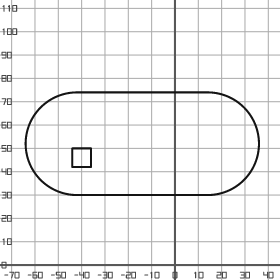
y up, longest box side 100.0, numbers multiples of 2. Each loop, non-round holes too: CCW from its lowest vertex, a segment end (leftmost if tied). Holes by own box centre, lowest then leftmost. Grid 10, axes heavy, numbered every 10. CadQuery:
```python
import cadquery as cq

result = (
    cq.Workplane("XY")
    .moveTo(-42.0, 30.0)
    .lineTo(14.0, 30.0)
    .threePointArc((36.0, 52.0), (14.0, 74.0))
    .lineTo(-42.0, 74.0)
    .threePointArc((-64.0, 52.0), (-42.0, 30.0))
    .close()
    .moveTo(-44.0, 42.0)
    .lineTo(-36.0, 42.0)
    .lineTo(-36.0, 50.0)
    .lineTo(-44.0, 50.0)
    .close()
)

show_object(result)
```